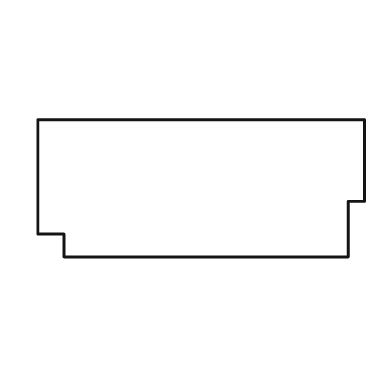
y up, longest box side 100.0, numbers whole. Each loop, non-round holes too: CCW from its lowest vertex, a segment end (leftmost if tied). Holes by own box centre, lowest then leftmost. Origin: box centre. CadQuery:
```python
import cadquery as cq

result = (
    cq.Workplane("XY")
    .moveTo(-42.0, -21.0)
    .lineTo(45.0, -21.0)
    .lineTo(45.0, -4.0)
    .lineTo(50.0, -4.0)
    .lineTo(50.0, 21.0)
    .lineTo(-50.0, 21.0)
    .lineTo(-50.0, -14.0)
    .lineTo(-42.0, -14.0)
    .close()
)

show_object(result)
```